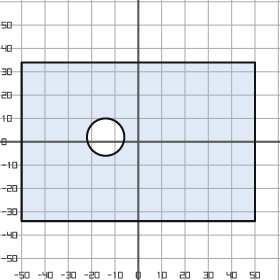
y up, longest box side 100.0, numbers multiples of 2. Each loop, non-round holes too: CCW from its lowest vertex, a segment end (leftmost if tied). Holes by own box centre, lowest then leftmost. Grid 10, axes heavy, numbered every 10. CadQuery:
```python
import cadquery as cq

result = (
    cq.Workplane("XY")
    .moveTo(-50.0, -34.0)
    .lineTo(50.0, -34.0)
    .lineTo(50.0, 34.0)
    .lineTo(-50.0, 34.0)
    .close()
    .moveTo(-14.0, 2.0)
    .circle(8.0)
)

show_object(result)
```